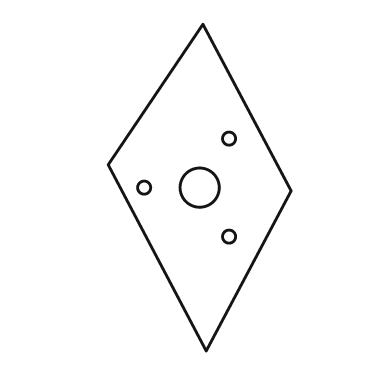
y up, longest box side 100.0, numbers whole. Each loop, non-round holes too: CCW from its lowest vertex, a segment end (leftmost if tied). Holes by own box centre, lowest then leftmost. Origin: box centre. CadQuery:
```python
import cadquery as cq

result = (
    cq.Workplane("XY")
    .moveTo(2.0, -50.0)
    .lineTo(28.0, -1.0)
    .lineTo(1.0, 50.0)
    .lineTo(-28.0, 7.0)
    .close()
    .moveTo(9.0, -15.0)
    .circle(2.0)
    .moveTo(-17.0, 0.0)
    .circle(2.0)
    .moveTo(0.0, 0.0)
    .circle(6.0)
    .moveTo(9.0, 15.0)
    .circle(2.0)
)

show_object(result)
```